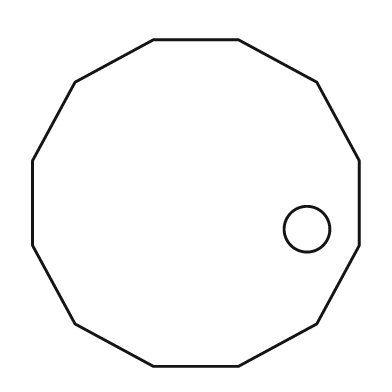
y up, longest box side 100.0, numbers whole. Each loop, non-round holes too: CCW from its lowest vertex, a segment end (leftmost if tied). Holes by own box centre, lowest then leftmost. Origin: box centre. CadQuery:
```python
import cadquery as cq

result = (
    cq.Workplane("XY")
    .moveTo(-13.0, -50.0)
    .lineTo(13.0, -50.0)
    .lineTo(37.0, -37.0)
    .lineTo(50.0, -13.0)
    .lineTo(50.0, 13.0)
    .lineTo(37.0, 37.0)
    .lineTo(13.0, 50.0)
    .lineTo(-13.0, 50.0)
    .lineTo(-37.0, 37.0)
    .lineTo(-50.0, 13.0)
    .lineTo(-50.0, -13.0)
    .lineTo(-37.0, -37.0)
    .close()
    .moveTo(34.0, -8.0)
    .circle(7.0)
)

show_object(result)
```